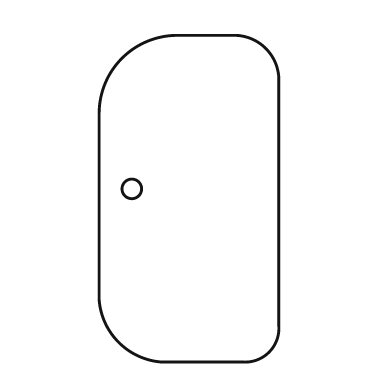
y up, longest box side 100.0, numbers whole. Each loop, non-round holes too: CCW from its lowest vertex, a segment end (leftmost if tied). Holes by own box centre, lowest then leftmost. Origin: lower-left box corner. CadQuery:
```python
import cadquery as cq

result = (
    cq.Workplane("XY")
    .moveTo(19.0, 0.0)
    .lineTo(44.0, 0.0)
    .threePointArc((52.0, 3.0), (55.0, 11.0))
    .lineTo(55.0, 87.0)
    .threePointArc((51.0, 96.0), (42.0, 100.0))
    .lineTo(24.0, 100.0)
    .threePointArc((7.0, 93.0), (0.0, 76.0))
    .lineTo(0.0, 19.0)
    .threePointArc((6.0, 6.0), (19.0, 0.0))
    .close()
    .moveTo(10.0, 53.0)
    .circle(3.0)
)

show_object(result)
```